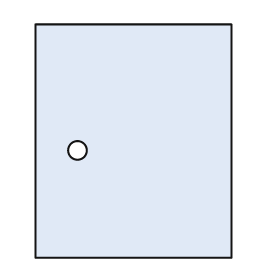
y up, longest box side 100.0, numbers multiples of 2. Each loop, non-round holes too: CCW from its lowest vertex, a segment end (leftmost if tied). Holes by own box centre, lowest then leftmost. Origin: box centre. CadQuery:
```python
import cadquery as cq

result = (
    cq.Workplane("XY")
    .moveTo(-42.0, -50.0)
    .lineTo(42.0, -50.0)
    .lineTo(42.0, 50.0)
    .lineTo(-42.0, 50.0)
    .close()
    .moveTo(-24.0, -4.0)
    .circle(4.0)
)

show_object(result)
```